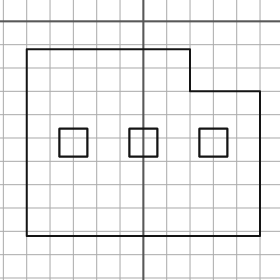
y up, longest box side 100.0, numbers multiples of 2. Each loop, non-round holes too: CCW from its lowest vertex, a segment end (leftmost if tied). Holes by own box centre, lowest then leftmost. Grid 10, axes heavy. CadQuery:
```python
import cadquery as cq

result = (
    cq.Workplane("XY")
    .moveTo(-50.0, -92.0)
    .lineTo(50.0, -92.0)
    .lineTo(50.0, -30.0)
    .lineTo(20.0, -30.0)
    .lineTo(20.0, -12.0)
    .lineTo(-50.0, -12.0)
    .close()
    .moveTo(-36.0, -58.0)
    .lineTo(-24.0, -58.0)
    .lineTo(-24.0, -46.0)
    .lineTo(-36.0, -46.0)
    .close()
    .moveTo(-6.0, -58.0)
    .lineTo(6.0, -58.0)
    .lineTo(6.0, -46.0)
    .lineTo(-6.0, -46.0)
    .close()
    .moveTo(24.0, -58.0)
    .lineTo(36.0, -58.0)
    .lineTo(36.0, -46.0)
    .lineTo(24.0, -46.0)
    .close()
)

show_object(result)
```